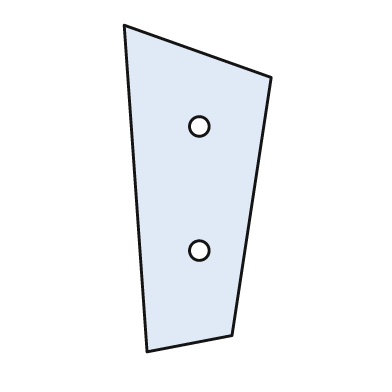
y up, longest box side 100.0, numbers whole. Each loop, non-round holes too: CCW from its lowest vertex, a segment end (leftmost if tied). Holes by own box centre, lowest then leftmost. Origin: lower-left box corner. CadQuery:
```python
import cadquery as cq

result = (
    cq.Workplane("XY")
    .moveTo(7.0, 0.0)
    .lineTo(33.0, 5.0)
    .lineTo(45.0, 84.0)
    .lineTo(0.0, 100.0)
    .close()
    .moveTo(23.0, 31.0)
    .circle(3.0)
    .moveTo(23.0, 69.0)
    .circle(3.0)
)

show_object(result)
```